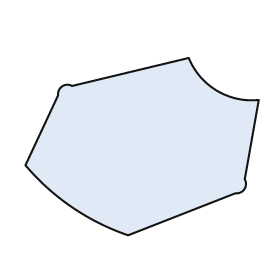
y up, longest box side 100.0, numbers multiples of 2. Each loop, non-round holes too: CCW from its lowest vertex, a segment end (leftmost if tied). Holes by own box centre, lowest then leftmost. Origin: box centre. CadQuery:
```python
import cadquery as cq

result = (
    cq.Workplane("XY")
    .moveTo(-6.0, -38.0)
    .lineTo(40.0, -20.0)
    .threePointArc((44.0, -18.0), (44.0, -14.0))
    .lineTo(50.0, 20.0)
    .threePointArc((32.0, 24.0), (20.0, 38.0))
    .lineTo(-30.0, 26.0)
    .threePointArc((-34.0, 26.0), (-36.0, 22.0))
    .lineTo(-50.0, -8.0)
    .threePointArc((-30.0, -26.0), (-6.0, -38.0))
    .close()
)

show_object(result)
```